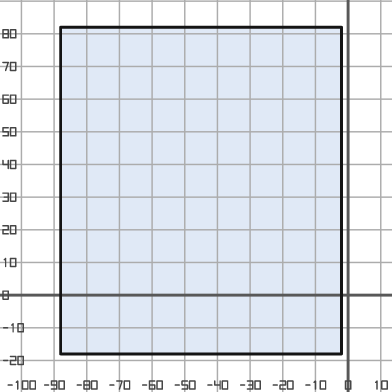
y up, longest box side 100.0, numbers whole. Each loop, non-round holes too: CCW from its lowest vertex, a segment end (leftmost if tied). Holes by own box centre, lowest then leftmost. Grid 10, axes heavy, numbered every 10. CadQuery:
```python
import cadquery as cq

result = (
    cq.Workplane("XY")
    .moveTo(-88.0, -18.0)
    .lineTo(-2.0, -18.0)
    .lineTo(-2.0, 82.0)
    .lineTo(-88.0, 82.0)
    .close()
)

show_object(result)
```